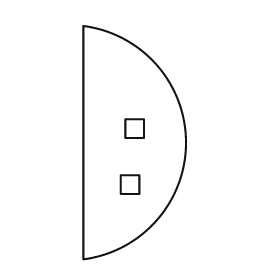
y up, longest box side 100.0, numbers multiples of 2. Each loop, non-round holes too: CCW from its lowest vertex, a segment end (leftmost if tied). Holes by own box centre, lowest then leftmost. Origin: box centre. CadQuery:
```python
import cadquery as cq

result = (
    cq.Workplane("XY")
    .moveTo(-22.0, -50.0)
    .threePointArc((22.0, 0.0), (-22.0, 50.0))
    .close()
    .moveTo(-6.0, -22.0)
    .lineTo(2.0, -22.0)
    .lineTo(2.0, -14.0)
    .lineTo(-6.0, -14.0)
    .close()
    .moveTo(-4.0, 2.0)
    .lineTo(4.0, 2.0)
    .lineTo(4.0, 10.0)
    .lineTo(-4.0, 10.0)
    .close()
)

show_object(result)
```